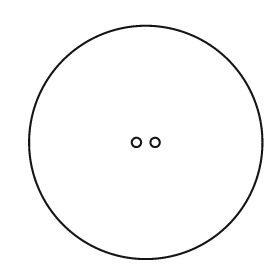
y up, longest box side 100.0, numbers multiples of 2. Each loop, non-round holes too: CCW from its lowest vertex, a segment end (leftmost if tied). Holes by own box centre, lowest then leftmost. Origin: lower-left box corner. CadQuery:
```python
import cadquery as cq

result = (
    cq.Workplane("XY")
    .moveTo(50.0, 50.0)
    .circle(50.0)
    .moveTo(46.0, 50.0)
    .circle(2.0)
    .moveTo(54.0, 50.0)
    .circle(2.0)
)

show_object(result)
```